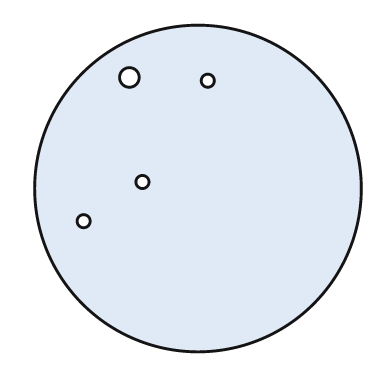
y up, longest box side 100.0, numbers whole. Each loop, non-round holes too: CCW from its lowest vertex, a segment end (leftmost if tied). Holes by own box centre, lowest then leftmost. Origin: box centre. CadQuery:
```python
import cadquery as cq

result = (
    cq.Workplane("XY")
    .moveTo(0.0, 0.0)
    .circle(50.0)
    .moveTo(-35.0, -10.0)
    .circle(2.0)
    .moveTo(-17.0, 2.0)
    .circle(2.0)
    .moveTo(3.0, 33.0)
    .circle(2.0)
    .moveTo(-21.0, 34.0)
    .circle(3.0)
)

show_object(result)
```